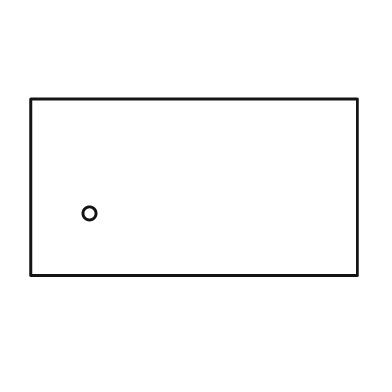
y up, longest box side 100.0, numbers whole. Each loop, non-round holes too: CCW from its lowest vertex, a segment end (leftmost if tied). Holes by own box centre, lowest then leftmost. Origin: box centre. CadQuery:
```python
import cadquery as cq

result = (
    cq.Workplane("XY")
    .moveTo(-50.0, -27.0)
    .lineTo(50.0, -27.0)
    .lineTo(50.0, 27.0)
    .lineTo(-50.0, 27.0)
    .close()
    .moveTo(-32.0, -8.0)
    .circle(2.0)
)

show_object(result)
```